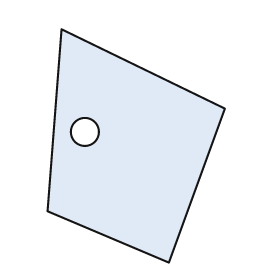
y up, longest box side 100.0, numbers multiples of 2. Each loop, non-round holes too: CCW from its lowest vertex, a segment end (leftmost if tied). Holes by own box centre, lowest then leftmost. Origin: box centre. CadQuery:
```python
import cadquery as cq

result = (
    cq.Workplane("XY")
    .moveTo(14.0, -50.0)
    .lineTo(38.0, 16.0)
    .lineTo(-32.0, 50.0)
    .lineTo(-38.0, -28.0)
    .close()
    .moveTo(-22.0, 6.0)
    .circle(6.0)
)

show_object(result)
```